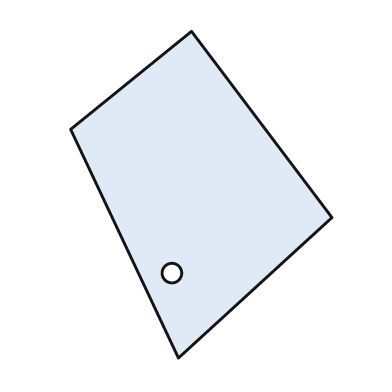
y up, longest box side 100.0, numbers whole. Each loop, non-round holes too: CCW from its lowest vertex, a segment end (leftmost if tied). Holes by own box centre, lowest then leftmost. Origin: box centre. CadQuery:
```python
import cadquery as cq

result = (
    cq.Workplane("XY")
    .moveTo(-7.0, -50.0)
    .lineTo(40.0, -7.0)
    .lineTo(-3.0, 50.0)
    .lineTo(-40.0, 20.0)
    .close()
    .moveTo(-9.0, -24.0)
    .circle(3.0)
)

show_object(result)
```